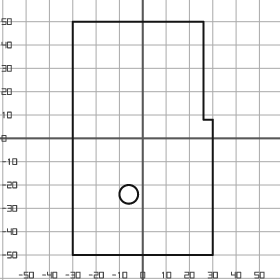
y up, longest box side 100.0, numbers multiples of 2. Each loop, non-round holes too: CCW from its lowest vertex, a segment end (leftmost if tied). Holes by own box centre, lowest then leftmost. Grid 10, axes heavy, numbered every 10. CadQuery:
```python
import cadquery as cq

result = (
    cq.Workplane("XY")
    .moveTo(-30.0, -50.0)
    .lineTo(30.0, -50.0)
    .lineTo(30.0, 8.0)
    .lineTo(26.0, 8.0)
    .lineTo(26.0, 50.0)
    .lineTo(-30.0, 50.0)
    .close()
    .moveTo(-6.0, -24.0)
    .circle(4.0)
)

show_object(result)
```